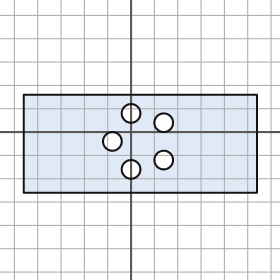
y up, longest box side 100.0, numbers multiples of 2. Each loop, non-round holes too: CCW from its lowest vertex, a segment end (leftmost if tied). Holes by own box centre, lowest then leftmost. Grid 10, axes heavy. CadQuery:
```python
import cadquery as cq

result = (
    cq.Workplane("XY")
    .moveTo(-46.0, -26.0)
    .lineTo(54.0, -26.0)
    .lineTo(54.0, 16.0)
    .lineTo(-46.0, 16.0)
    .close()
    .moveTo(0.0, -16.0)
    .circle(4.0)
    .moveTo(14.0, -12.0)
    .circle(4.0)
    .moveTo(-8.0, -4.0)
    .circle(4.0)
    .moveTo(14.0, 4.0)
    .circle(4.0)
    .moveTo(0.0, 8.0)
    .circle(4.0)
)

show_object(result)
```